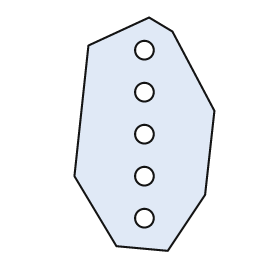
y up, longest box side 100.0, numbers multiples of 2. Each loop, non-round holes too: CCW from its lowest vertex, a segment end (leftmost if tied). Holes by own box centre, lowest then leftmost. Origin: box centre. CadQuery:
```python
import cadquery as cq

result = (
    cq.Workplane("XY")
    .moveTo(10.0, -50.0)
    .lineTo(26.0, -26.0)
    .lineTo(30.0, 10.0)
    .lineTo(12.0, 44.0)
    .lineTo(2.0, 50.0)
    .lineTo(-24.0, 38.0)
    .lineTo(-30.0, -18.0)
    .lineTo(-12.0, -48.0)
    .close()
    .moveTo(0.0, -36.0)
    .circle(4.0)
    .moveTo(0.0, -18.0)
    .circle(4.0)
    .moveTo(0.0, 0.0)
    .circle(4.0)
    .moveTo(0.0, 18.0)
    .circle(4.0)
    .moveTo(0.0, 36.0)
    .circle(4.0)
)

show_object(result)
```